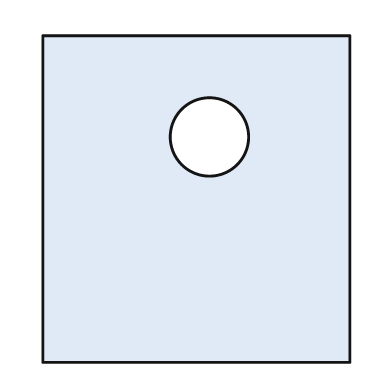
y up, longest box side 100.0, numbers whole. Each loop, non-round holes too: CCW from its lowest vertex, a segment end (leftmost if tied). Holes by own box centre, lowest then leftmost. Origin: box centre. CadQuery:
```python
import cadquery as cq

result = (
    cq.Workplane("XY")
    .moveTo(-47.0, -50.0)
    .lineTo(47.0, -50.0)
    .lineTo(47.0, 50.0)
    .lineTo(-47.0, 50.0)
    .close()
    .moveTo(4.0, 19.0)
    .circle(12.0)
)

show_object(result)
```